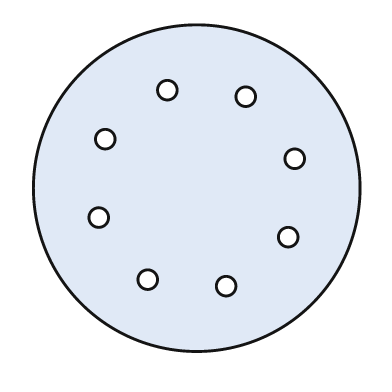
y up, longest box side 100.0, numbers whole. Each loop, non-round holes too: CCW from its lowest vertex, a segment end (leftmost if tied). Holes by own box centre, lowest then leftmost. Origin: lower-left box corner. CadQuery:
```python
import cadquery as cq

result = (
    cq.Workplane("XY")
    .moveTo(50.0, 50.0)
    .circle(50.0)
    .moveTo(59.0, 20.0)
    .circle(3.0)
    .moveTo(35.0, 22.0)
    .circle(3.0)
    .moveTo(78.0, 35.0)
    .circle(3.0)
    .moveTo(20.0, 41.0)
    .circle(3.0)
    .moveTo(80.0, 59.0)
    .circle(3.0)
    .moveTo(22.0, 65.0)
    .circle(3.0)
    .moveTo(65.0, 78.0)
    .circle(3.0)
    .moveTo(41.0, 80.0)
    .circle(3.0)
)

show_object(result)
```